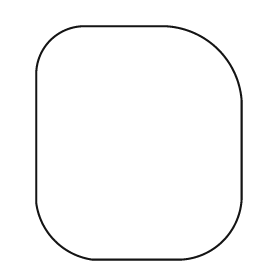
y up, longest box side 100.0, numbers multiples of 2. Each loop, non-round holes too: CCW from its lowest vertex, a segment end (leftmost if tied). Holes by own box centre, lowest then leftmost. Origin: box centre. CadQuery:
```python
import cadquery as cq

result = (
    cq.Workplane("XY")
    .moveTo(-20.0, -50.0)
    .lineTo(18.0, -50.0)
    .threePointArc((36.0, -42.0), (44.0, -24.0))
    .lineTo(44.0, 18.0)
    .threePointArc((34.0, 40.0), (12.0, 50.0))
    .lineTo(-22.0, 50.0)
    .threePointArc((-38.0, 44.0), (-44.0, 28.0))
    .lineTo(-44.0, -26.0)
    .threePointArc((-36.0, -42.0), (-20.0, -50.0))
    .close()
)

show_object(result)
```